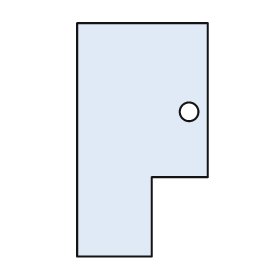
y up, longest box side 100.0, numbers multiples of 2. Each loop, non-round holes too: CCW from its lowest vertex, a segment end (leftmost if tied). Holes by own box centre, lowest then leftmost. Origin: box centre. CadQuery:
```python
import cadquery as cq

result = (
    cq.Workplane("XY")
    .moveTo(-28.0, -50.0)
    .lineTo(4.0, -50.0)
    .lineTo(4.0, -16.0)
    .lineTo(28.0, -16.0)
    .lineTo(28.0, 50.0)
    .lineTo(-28.0, 50.0)
    .close()
    .moveTo(20.0, 12.0)
    .circle(4.0)
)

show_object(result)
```